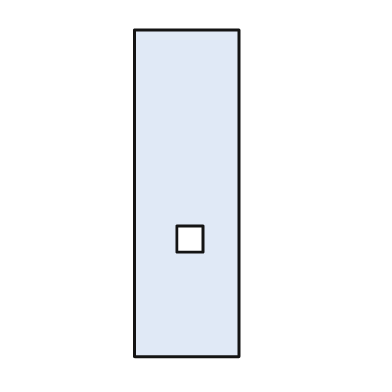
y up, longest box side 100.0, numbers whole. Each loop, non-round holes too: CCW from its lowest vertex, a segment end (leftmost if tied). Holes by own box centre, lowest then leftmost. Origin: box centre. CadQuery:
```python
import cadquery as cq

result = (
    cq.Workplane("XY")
    .moveTo(-16.0, -50.0)
    .lineTo(16.0, -50.0)
    .lineTo(16.0, 50.0)
    .lineTo(-16.0, 50.0)
    .close()
    .moveTo(-3.0, -18.0)
    .lineTo(5.0, -18.0)
    .lineTo(5.0, -10.0)
    .lineTo(-3.0, -10.0)
    .close()
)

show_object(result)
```